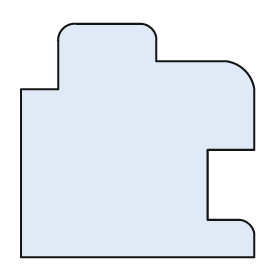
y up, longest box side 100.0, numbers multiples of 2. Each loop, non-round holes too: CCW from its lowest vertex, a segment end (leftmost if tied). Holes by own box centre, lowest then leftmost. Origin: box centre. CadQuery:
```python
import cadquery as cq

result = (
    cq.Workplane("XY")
    .moveTo(-50.0, -50.0)
    .lineTo(50.0, -50.0)
    .lineTo(50.0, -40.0)
    .threePointArc((48.0, -36.0), (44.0, -34.0))
    .lineTo(30.0, -34.0)
    .lineTo(30.0, -4.0)
    .lineTo(50.0, -4.0)
    .lineTo(50.0, 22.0)
    .threePointArc((46.0, 30.0), (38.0, 34.0))
    .lineTo(8.0, 34.0)
    .lineTo(8.0, 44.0)
    .threePointArc((6.0, 48.0), (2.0, 50.0))
    .lineTo(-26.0, 50.0)
    .threePointArc((-32.0, 48.0), (-34.0, 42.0))
    .lineTo(-34.0, 22.0)
    .lineTo(-50.0, 22.0)
    .close()
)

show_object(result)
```